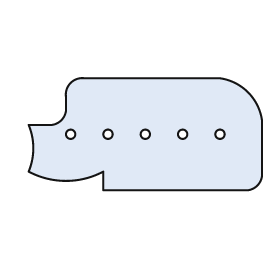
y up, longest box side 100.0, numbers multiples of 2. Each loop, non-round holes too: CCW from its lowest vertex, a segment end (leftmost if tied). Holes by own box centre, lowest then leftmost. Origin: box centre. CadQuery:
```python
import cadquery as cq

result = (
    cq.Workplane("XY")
    .moveTo(-18.0, -24.0)
    .lineTo(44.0, -24.0)
    .threePointArc((48.0, -22.0), (50.0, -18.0))
    .lineTo(50.0, 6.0)
    .threePointArc((44.0, 18.0), (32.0, 24.0))
    .lineTo(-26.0, 24.0)
    .threePointArc((-32.0, 22.0), (-34.0, 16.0))
    .lineTo(-34.0, 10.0)
    .threePointArc((-36.0, 6.0), (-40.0, 4.0))
    .lineTo(-50.0, 4.0)
    .threePointArc((-48.0, -6.0), (-50.0, -16.0))
    .threePointArc((-34.0, -20.0), (-18.0, -16.0))
    .close()
    .moveTo(-32.0, 0.0)
    .circle(2.0)
    .moveTo(-16.0, 0.0)
    .circle(2.0)
    .moveTo(0.0, 0.0)
    .circle(2.0)
    .moveTo(16.0, 0.0)
    .circle(2.0)
    .moveTo(32.0, 0.0)
    .circle(2.0)
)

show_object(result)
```